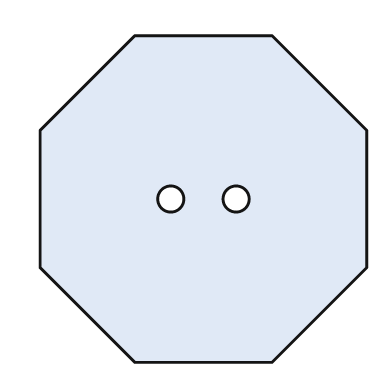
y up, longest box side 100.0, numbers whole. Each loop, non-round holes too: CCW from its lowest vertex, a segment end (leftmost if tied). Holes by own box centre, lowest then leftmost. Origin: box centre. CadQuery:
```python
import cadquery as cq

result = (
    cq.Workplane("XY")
    .moveTo(-21.0, -50.0)
    .lineTo(21.0, -50.0)
    .lineTo(50.0, -21.0)
    .lineTo(50.0, 21.0)
    .lineTo(21.0, 50.0)
    .lineTo(-21.0, 50.0)
    .lineTo(-50.0, 21.0)
    .lineTo(-50.0, -21.0)
    .close()
    .moveTo(-10.0, 0.0)
    .circle(4.0)
    .moveTo(10.0, 0.0)
    .circle(4.0)
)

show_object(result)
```